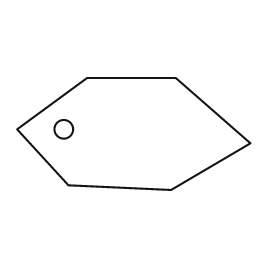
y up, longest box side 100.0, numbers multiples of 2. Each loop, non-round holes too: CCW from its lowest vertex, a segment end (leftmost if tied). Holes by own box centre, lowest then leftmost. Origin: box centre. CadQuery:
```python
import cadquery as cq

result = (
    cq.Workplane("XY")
    .moveTo(16.0, -24.0)
    .lineTo(50.0, -4.0)
    .lineTo(18.0, 24.0)
    .lineTo(-20.0, 24.0)
    .lineTo(-50.0, 2.0)
    .lineTo(-28.0, -22.0)
    .close()
    .moveTo(-30.0, 2.0)
    .circle(4.0)
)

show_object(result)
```